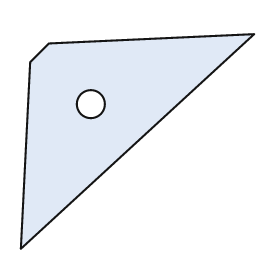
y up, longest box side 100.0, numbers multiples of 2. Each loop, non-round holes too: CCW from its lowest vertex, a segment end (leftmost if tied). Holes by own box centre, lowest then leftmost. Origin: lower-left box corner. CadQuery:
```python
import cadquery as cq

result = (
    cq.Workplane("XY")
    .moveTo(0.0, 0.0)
    .lineTo(100.0, 92.0)
    .lineTo(12.0, 88.0)
    .lineTo(4.0, 80.0)
    .close()
    .moveTo(30.0, 62.0)
    .circle(6.0)
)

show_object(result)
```